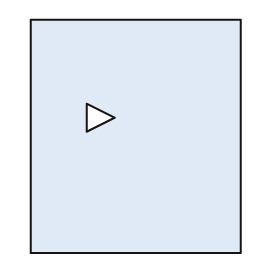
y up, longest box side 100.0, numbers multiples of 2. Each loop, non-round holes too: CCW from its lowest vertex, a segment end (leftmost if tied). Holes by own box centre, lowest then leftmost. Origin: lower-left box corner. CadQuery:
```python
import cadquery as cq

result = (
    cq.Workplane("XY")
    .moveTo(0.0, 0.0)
    .lineTo(90.0, 0.0)
    .lineTo(90.0, 100.0)
    .lineTo(0.0, 100.0)
    .close()
    .moveTo(24.0, 52.0)
    .lineTo(36.0, 58.0)
    .lineTo(24.0, 64.0)
    .close()
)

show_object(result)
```